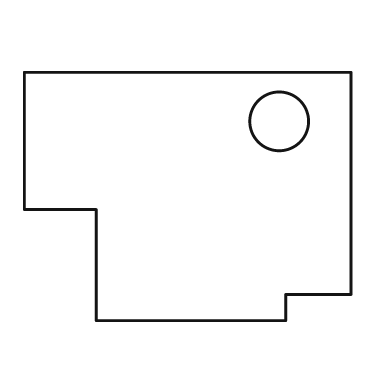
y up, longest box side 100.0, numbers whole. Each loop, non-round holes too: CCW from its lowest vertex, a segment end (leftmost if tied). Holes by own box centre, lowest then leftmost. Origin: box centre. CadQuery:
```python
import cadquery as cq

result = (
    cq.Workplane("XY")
    .moveTo(-28.0, -38.0)
    .lineTo(30.0, -38.0)
    .lineTo(30.0, -30.0)
    .lineTo(50.0, -30.0)
    .lineTo(50.0, 38.0)
    .lineTo(-50.0, 38.0)
    .lineTo(-50.0, -4.0)
    .lineTo(-28.0, -4.0)
    .close()
    .moveTo(28.0, 23.0)
    .circle(9.0)
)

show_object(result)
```